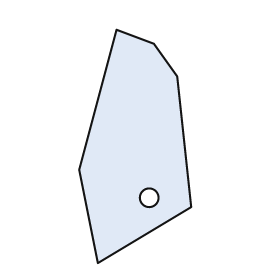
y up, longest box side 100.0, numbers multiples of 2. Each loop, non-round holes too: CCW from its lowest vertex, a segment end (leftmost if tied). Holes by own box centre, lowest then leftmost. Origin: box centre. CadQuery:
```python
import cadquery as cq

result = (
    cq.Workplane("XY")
    .moveTo(-16.0, -50.0)
    .lineTo(24.0, -26.0)
    .lineTo(18.0, 30.0)
    .lineTo(8.0, 44.0)
    .lineTo(-8.0, 50.0)
    .lineTo(-24.0, -10.0)
    .close()
    .moveTo(6.0, -22.0)
    .circle(4.0)
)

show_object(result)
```